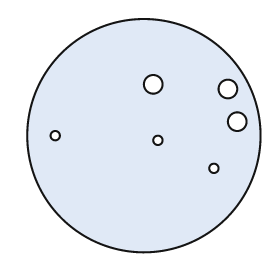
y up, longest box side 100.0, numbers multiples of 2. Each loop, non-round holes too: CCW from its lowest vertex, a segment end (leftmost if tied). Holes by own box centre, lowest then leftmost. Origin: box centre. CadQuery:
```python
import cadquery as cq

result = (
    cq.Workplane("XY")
    .moveTo(0.0, 0.0)
    .circle(50.0)
    .moveTo(30.0, -14.0)
    .circle(2.0)
    .moveTo(6.0, -2.0)
    .circle(2.0)
    .moveTo(-38.0, 0.0)
    .circle(2.0)
    .moveTo(40.0, 6.0)
    .circle(4.0)
    .moveTo(36.0, 20.0)
    .circle(4.0)
    .moveTo(4.0, 22.0)
    .circle(4.0)
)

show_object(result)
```